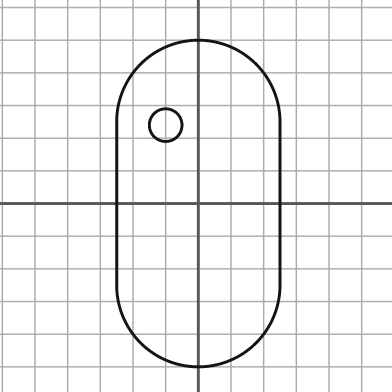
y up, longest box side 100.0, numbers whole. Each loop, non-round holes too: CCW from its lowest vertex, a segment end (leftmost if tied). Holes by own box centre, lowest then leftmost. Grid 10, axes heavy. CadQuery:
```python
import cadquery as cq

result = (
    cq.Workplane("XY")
    .moveTo(-25.0, -25.0)
    .threePointArc((0.0, -50.0), (25.0, -25.0))
    .lineTo(25.0, 25.0)
    .threePointArc((0.0, 50.0), (-25.0, 25.0))
    .close()
    .moveTo(-10.0, 24.0)
    .circle(5.0)
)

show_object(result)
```